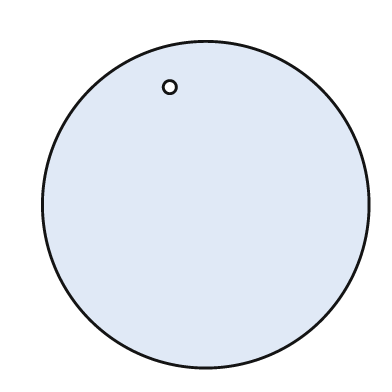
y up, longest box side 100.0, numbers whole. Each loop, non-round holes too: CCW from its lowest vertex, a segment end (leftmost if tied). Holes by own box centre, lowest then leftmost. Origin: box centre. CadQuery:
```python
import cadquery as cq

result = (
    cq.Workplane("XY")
    .moveTo(0.0, 0.0)
    .circle(50.0)
    .moveTo(-11.0, 36.0)
    .circle(2.0)
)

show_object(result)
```